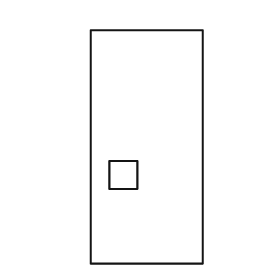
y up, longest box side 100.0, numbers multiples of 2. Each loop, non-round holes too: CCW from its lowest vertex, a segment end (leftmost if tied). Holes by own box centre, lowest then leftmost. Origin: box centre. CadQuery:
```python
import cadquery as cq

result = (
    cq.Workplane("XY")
    .moveTo(-24.0, -50.0)
    .lineTo(24.0, -50.0)
    .lineTo(24.0, 50.0)
    .lineTo(-24.0, 50.0)
    .close()
    .moveTo(-16.0, -18.0)
    .lineTo(-4.0, -18.0)
    .lineTo(-4.0, -6.0)
    .lineTo(-16.0, -6.0)
    .close()
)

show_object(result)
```